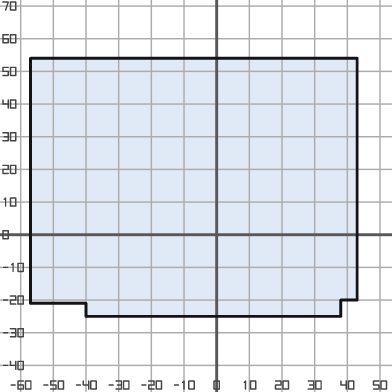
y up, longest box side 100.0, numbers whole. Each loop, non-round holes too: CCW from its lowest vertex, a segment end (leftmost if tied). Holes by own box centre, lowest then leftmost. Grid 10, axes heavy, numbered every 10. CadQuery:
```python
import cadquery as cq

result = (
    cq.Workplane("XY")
    .moveTo(-40.0, -25.0)
    .lineTo(38.0, -25.0)
    .lineTo(38.0, -20.0)
    .lineTo(43.0, -20.0)
    .lineTo(43.0, 54.0)
    .lineTo(-57.0, 54.0)
    .lineTo(-57.0, -21.0)
    .lineTo(-40.0, -21.0)
    .close()
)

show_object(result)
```